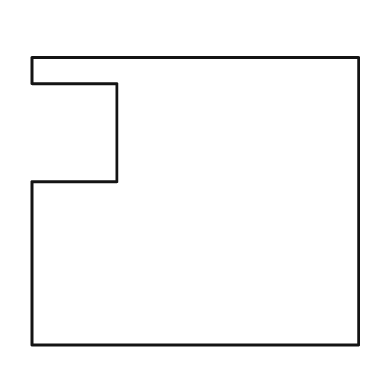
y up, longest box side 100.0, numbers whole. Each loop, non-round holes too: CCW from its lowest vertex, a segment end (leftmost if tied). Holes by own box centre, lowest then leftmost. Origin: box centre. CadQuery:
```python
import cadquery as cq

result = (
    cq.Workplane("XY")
    .moveTo(-50.0, -44.0)
    .lineTo(50.0, -44.0)
    .lineTo(50.0, 44.0)
    .lineTo(-50.0, 44.0)
    .lineTo(-50.0, 36.0)
    .lineTo(-24.0, 36.0)
    .lineTo(-24.0, 6.0)
    .lineTo(-50.0, 6.0)
    .close()
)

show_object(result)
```